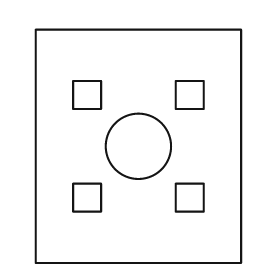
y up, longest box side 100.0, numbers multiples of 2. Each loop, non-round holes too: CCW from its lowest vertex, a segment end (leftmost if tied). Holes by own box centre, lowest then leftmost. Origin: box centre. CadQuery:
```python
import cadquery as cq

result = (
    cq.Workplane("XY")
    .moveTo(-44.0, -50.0)
    .lineTo(44.0, -50.0)
    .lineTo(44.0, 50.0)
    .lineTo(-44.0, 50.0)
    .close()
    .moveTo(-28.0, -28.0)
    .lineTo(-16.0, -28.0)
    .lineTo(-16.0, -16.0)
    .lineTo(-28.0, -16.0)
    .close()
    .moveTo(16.0, -28.0)
    .lineTo(28.0, -28.0)
    .lineTo(28.0, -16.0)
    .lineTo(16.0, -16.0)
    .close()
    .moveTo(0.0, 0.0)
    .circle(14.0)
    .moveTo(-28.0, 16.0)
    .lineTo(-16.0, 16.0)
    .lineTo(-16.0, 28.0)
    .lineTo(-28.0, 28.0)
    .close()
    .moveTo(16.0, 16.0)
    .lineTo(28.0, 16.0)
    .lineTo(28.0, 28.0)
    .lineTo(16.0, 28.0)
    .close()
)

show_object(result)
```